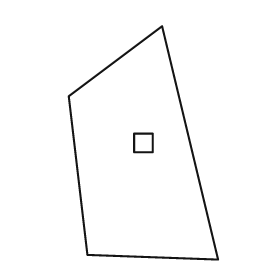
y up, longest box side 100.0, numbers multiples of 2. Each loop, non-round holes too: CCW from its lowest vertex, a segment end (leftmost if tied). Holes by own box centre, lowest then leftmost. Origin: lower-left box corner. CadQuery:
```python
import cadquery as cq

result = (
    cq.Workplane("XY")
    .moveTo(64.0, 0.0)
    .lineTo(40.0, 100.0)
    .lineTo(0.0, 70.0)
    .lineTo(8.0, 2.0)
    .close()
    .moveTo(28.0, 46.0)
    .lineTo(36.0, 46.0)
    .lineTo(36.0, 54.0)
    .lineTo(28.0, 54.0)
    .close()
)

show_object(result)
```